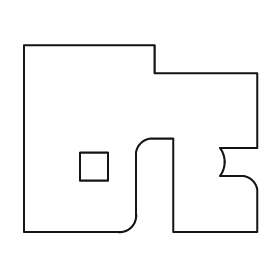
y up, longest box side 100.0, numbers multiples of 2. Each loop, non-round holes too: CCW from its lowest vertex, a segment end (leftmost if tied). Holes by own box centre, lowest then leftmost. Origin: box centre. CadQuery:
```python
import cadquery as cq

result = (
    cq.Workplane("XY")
    .moveTo(-50.0, -40.0)
    .lineTo(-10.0, -40.0)
    .threePointArc((-4.0, -38.0), (-2.0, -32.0))
    .lineTo(-2.0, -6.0)
    .threePointArc((0.0, -2.0), (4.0, 0.0))
    .lineTo(14.0, 0.0)
    .lineTo(14.0, -40.0)
    .lineTo(50.0, -40.0)
    .lineTo(50.0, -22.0)
    .threePointArc((48.0, -18.0), (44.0, -16.0))
    .lineTo(34.0, -16.0)
    .threePointArc((36.0, -10.0), (34.0, -4.0))
    .lineTo(50.0, -4.0)
    .lineTo(50.0, 28.0)
    .lineTo(6.0, 28.0)
    .lineTo(6.0, 40.0)
    .lineTo(-50.0, 40.0)
    .close()
    .moveTo(-26.0, -18.0)
    .lineTo(-14.0, -18.0)
    .lineTo(-14.0, -6.0)
    .lineTo(-26.0, -6.0)
    .close()
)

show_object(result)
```